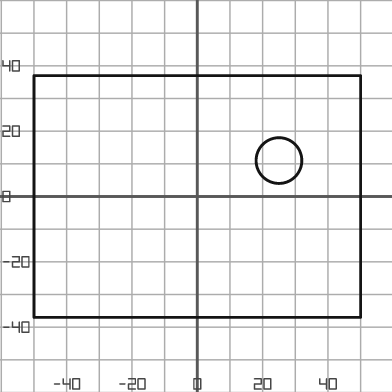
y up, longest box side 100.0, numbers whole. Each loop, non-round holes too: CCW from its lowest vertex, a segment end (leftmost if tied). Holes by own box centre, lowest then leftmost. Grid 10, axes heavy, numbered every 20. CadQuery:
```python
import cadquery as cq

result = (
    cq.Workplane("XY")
    .moveTo(-50.0, -37.0)
    .lineTo(50.0, -37.0)
    .lineTo(50.0, 37.0)
    .lineTo(-50.0, 37.0)
    .close()
    .moveTo(25.0, 11.0)
    .circle(7.0)
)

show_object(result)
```